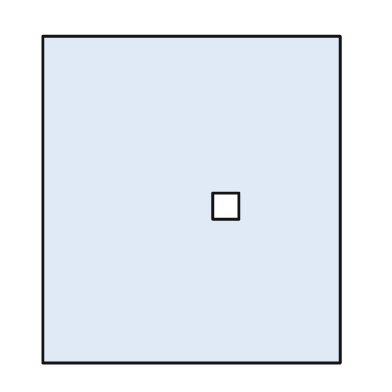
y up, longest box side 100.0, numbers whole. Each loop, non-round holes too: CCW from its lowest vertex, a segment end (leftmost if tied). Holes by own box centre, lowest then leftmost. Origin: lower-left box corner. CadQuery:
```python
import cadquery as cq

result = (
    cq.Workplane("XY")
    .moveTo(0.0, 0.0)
    .lineTo(91.0, 0.0)
    .lineTo(91.0, 100.0)
    .lineTo(0.0, 100.0)
    .close()
    .moveTo(52.0, 44.0)
    .lineTo(60.0, 44.0)
    .lineTo(60.0, 52.0)
    .lineTo(52.0, 52.0)
    .close()
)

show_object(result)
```